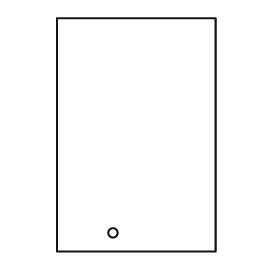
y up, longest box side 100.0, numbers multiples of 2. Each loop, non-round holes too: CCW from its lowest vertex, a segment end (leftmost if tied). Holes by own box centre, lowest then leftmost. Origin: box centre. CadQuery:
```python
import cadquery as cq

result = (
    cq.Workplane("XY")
    .moveTo(-34.0, -50.0)
    .lineTo(34.0, -50.0)
    .lineTo(34.0, 50.0)
    .lineTo(-34.0, 50.0)
    .close()
    .moveTo(-10.0, -42.0)
    .circle(2.0)
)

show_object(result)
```